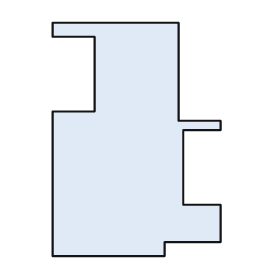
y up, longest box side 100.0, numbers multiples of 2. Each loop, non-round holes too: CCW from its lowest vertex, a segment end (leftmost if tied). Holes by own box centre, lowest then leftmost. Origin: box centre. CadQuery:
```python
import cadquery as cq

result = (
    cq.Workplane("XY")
    .moveTo(-36.0, -50.0)
    .lineTo(12.0, -50.0)
    .lineTo(12.0, -44.0)
    .lineTo(36.0, -44.0)
    .lineTo(36.0, -28.0)
    .lineTo(20.0, -28.0)
    .lineTo(20.0, 4.0)
    .lineTo(36.0, 4.0)
    .lineTo(36.0, 8.0)
    .lineTo(18.0, 8.0)
    .lineTo(18.0, 50.0)
    .lineTo(-36.0, 50.0)
    .lineTo(-36.0, 44.0)
    .lineTo(-18.0, 44.0)
    .lineTo(-18.0, 12.0)
    .lineTo(-36.0, 12.0)
    .close()
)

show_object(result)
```